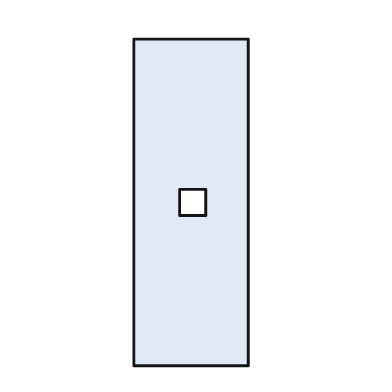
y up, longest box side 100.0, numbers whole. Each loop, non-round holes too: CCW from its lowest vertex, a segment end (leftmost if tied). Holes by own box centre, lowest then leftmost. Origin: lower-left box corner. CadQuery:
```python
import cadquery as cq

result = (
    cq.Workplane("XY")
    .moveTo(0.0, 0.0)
    .lineTo(35.0, 0.0)
    .lineTo(35.0, 100.0)
    .lineTo(0.0, 100.0)
    .close()
    .moveTo(14.0, 46.0)
    .lineTo(22.0, 46.0)
    .lineTo(22.0, 54.0)
    .lineTo(14.0, 54.0)
    .close()
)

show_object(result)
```